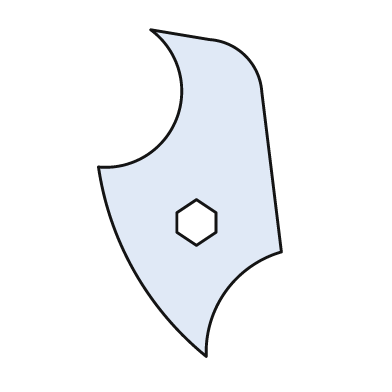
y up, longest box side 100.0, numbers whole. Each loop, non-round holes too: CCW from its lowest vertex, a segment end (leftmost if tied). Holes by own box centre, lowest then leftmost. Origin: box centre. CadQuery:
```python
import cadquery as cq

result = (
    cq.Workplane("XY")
    .moveTo(5.0, -50.0)
    .threePointArc((11.0, -30.0), (28.0, -18.0))
    .lineTo(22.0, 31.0)
    .threePointArc((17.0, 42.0), (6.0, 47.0))
    .lineTo(-12.0, 50.0)
    .threePointArc((-4.0, 23.0), (-28.0, 8.0))
    .threePointArc((-17.0, -24.0), (5.0, -50.0))
    .close()
    .moveTo(2.0, -16.0)
    .lineTo(8.0, -12.0)
    .lineTo(8.0, -6.0)
    .lineTo(2.0, -2.0)
    .lineTo(-4.0, -6.0)
    .lineTo(-4.0, -12.0)
    .close()
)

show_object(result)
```